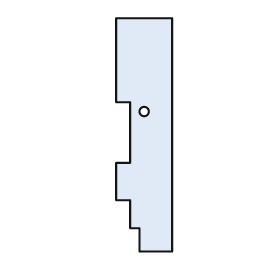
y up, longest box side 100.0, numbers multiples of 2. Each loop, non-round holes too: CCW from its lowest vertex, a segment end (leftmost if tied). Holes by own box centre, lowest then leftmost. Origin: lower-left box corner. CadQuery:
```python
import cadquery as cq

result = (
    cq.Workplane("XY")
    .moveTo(10.0, 0.0)
    .lineTo(24.0, 0.0)
    .lineTo(24.0, 100.0)
    .lineTo(0.0, 100.0)
    .lineTo(0.0, 64.0)
    .lineTo(6.0, 64.0)
    .lineTo(6.0, 38.0)
    .lineTo(0.0, 38.0)
    .lineTo(0.0, 22.0)
    .lineTo(6.0, 22.0)
    .lineTo(6.0, 10.0)
    .lineTo(10.0, 10.0)
    .close()
    .moveTo(12.0, 60.0)
    .circle(2.0)
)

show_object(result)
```